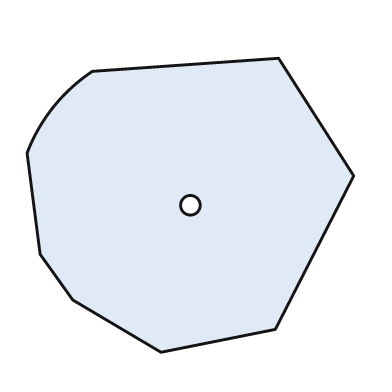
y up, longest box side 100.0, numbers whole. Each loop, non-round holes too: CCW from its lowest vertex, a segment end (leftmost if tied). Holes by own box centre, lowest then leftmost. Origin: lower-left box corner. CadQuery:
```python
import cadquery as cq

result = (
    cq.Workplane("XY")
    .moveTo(41.0, 0.0)
    .lineTo(76.0, 7.0)
    .lineTo(100.0, 54.0)
    .lineTo(77.0, 90.0)
    .lineTo(20.0, 86.0)
    .threePointArc((8.0, 75.0), (0.0, 61.0))
    .lineTo(4.0, 30.0)
    .lineTo(14.0, 16.0)
    .close()
    .moveTo(50.0, 45.0)
    .circle(3.0)
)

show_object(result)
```